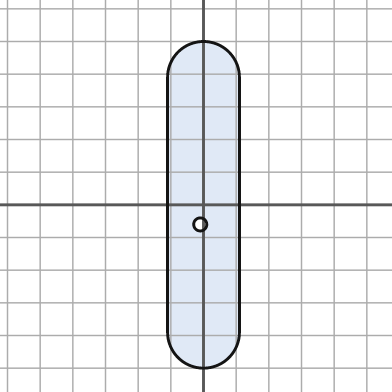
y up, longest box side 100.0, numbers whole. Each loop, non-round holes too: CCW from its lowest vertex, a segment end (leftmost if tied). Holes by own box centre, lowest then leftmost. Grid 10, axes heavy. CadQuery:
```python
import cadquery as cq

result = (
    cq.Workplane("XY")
    .moveTo(-11.0, -39.0)
    .threePointArc((0.0, -50.0), (11.0, -39.0))
    .lineTo(11.0, 39.0)
    .threePointArc((0.0, 50.0), (-11.0, 39.0))
    .close()
    .moveTo(-1.0, -6.0)
    .circle(2.0)
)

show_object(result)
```